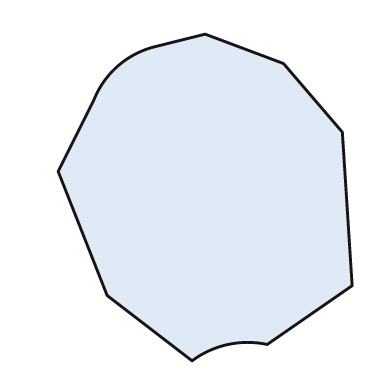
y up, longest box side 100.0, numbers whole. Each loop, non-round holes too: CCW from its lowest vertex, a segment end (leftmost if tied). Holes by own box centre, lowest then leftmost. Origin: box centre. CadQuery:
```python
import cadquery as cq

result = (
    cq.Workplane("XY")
    .moveTo(-4.0, -50.0)
    .threePointArc((7.0, -45.0), (19.0, -45.0))
    .lineTo(45.0, -27.0)
    .lineTo(42.0, 20.0)
    .lineTo(24.0, 41.0)
    .lineTo(0.0, 50.0)
    .lineTo(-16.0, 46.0)
    .threePointArc((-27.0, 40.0), (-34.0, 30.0))
    .lineTo(-45.0, 8.0)
    .lineTo(-30.0, -30.0)
    .close()
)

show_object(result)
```